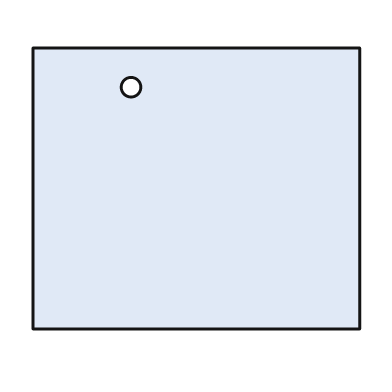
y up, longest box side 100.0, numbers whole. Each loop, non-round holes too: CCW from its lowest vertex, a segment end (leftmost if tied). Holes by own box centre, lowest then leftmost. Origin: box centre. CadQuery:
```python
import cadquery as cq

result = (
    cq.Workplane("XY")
    .moveTo(-50.0, -43.0)
    .lineTo(50.0, -43.0)
    .lineTo(50.0, 43.0)
    .lineTo(-50.0, 43.0)
    .close()
    .moveTo(-20.0, 31.0)
    .circle(3.0)
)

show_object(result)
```